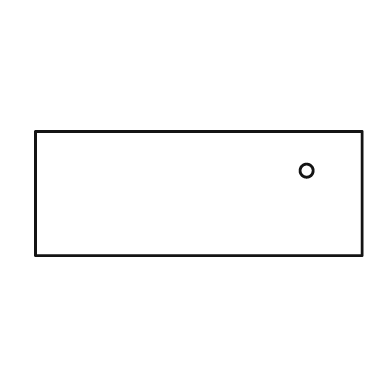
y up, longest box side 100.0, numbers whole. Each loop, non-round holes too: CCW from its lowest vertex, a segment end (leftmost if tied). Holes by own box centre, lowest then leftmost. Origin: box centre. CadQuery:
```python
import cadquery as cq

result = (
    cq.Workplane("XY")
    .moveTo(-50.0, -19.0)
    .lineTo(50.0, -19.0)
    .lineTo(50.0, 19.0)
    .lineTo(-50.0, 19.0)
    .close()
    .moveTo(33.0, 7.0)
    .circle(2.0)
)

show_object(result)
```